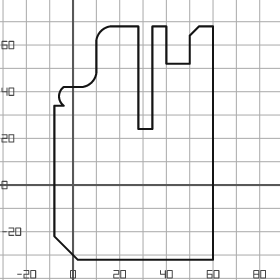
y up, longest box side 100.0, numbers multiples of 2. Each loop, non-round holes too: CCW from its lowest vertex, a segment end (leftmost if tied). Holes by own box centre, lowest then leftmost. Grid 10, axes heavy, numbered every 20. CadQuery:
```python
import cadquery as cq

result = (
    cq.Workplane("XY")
    .moveTo(2.0, -32.0)
    .lineTo(60.0, -32.0)
    .lineTo(60.0, 68.0)
    .lineTo(54.0, 68.0)
    .lineTo(50.0, 64.0)
    .lineTo(50.0, 52.0)
    .lineTo(40.0, 52.0)
    .lineTo(40.0, 68.0)
    .lineTo(34.0, 68.0)
    .lineTo(34.0, 24.0)
    .lineTo(28.0, 24.0)
    .lineTo(28.0, 68.0)
    .lineTo(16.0, 68.0)
    .threePointArc((12.0, 66.0), (10.0, 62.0))
    .lineTo(10.0, 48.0)
    .threePointArc((8.0, 44.0), (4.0, 42.0))
    .lineTo(-4.0, 42.0)
    .threePointArc((-6.0, 38.0), (-4.0, 34.0))
    .lineTo(-8.0, 34.0)
    .lineTo(-8.0, -22.0)
    .close()
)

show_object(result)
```